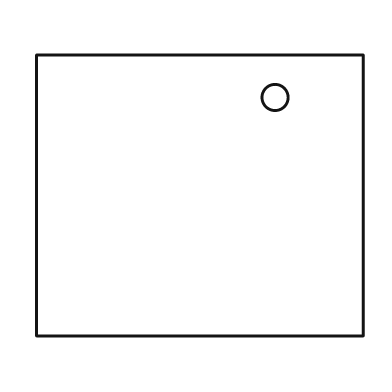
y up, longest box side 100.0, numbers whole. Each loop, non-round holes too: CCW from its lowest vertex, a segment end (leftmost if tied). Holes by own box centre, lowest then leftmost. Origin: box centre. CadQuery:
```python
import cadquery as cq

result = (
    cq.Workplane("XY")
    .moveTo(-50.0, -43.0)
    .lineTo(50.0, -43.0)
    .lineTo(50.0, 43.0)
    .lineTo(-50.0, 43.0)
    .close()
    .moveTo(23.0, 30.0)
    .circle(4.0)
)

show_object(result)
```